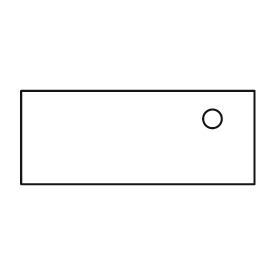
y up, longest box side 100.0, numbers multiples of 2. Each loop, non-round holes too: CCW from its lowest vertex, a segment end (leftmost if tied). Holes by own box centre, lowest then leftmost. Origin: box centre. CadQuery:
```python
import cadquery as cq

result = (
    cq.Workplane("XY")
    .moveTo(-50.0, -20.0)
    .lineTo(50.0, -20.0)
    .lineTo(50.0, 20.0)
    .lineTo(-50.0, 20.0)
    .close()
    .moveTo(32.0, 8.0)
    .circle(4.0)
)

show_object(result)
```